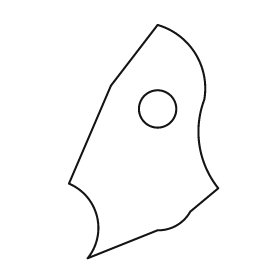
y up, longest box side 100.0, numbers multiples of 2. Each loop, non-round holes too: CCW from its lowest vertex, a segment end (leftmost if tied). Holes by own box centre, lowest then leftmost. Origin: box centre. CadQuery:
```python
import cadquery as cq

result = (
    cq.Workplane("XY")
    .moveTo(-24.0, -50.0)
    .lineTo(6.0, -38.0)
    .threePointArc((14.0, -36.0), (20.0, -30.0))
    .lineTo(32.0, -20.0)
    .threePointArc((24.0, -2.0), (26.0, 18.0))
    .threePointArc((22.0, 38.0), (6.0, 50.0))
    .lineTo(-14.0, 24.0)
    .lineTo(-32.0, -18.0)
    .threePointArc((-20.0, -32.0), (-24.0, -50.0))
    .close()
    .moveTo(6.0, 14.0)
    .circle(8.0)
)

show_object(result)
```